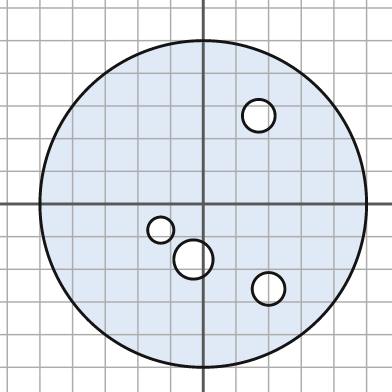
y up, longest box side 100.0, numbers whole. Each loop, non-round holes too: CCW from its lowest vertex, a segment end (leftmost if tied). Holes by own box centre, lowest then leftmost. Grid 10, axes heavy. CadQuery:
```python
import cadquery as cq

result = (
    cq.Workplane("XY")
    .moveTo(0.0, 0.0)
    .circle(50.0)
    .moveTo(20.0, -26.0)
    .circle(5.0)
    .moveTo(-3.0, -17.0)
    .circle(6.0)
    .moveTo(-13.0, -8.0)
    .circle(4.0)
    .moveTo(17.0, 27.0)
    .circle(5.0)
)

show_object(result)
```